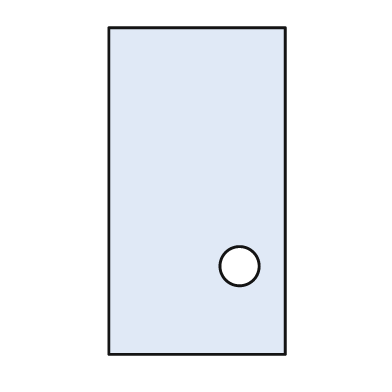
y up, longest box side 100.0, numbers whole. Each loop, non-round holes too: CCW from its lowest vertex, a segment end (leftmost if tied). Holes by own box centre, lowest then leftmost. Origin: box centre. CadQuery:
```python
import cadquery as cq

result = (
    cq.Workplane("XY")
    .moveTo(-27.0, -50.0)
    .lineTo(27.0, -50.0)
    .lineTo(27.0, 50.0)
    .lineTo(-27.0, 50.0)
    .close()
    .moveTo(13.0, -23.0)
    .circle(6.0)
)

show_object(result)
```